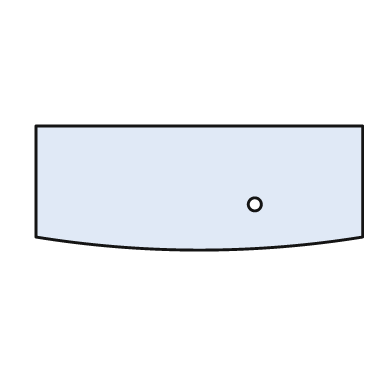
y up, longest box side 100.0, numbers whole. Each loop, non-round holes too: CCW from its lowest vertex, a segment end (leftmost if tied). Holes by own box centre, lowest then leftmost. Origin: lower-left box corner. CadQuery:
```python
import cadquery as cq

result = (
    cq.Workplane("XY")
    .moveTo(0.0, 4.0)
    .threePointArc((50.0, 0.0), (100.0, 4.0))
    .lineTo(100.0, 38.0)
    .lineTo(0.0, 38.0)
    .close()
    .moveTo(67.0, 14.0)
    .circle(2.0)
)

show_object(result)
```